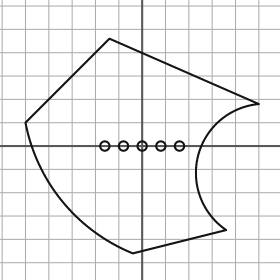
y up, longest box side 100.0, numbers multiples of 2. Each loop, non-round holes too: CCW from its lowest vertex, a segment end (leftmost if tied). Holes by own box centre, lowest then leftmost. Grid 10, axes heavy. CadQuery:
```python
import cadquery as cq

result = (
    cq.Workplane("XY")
    .moveTo(-4.0, -46.0)
    .lineTo(36.0, -36.0)
    .threePointArc((24.0, -4.0), (50.0, 18.0))
    .lineTo(-14.0, 46.0)
    .lineTo(-50.0, 10.0)
    .threePointArc((-34.0, -24.0), (-4.0, -46.0))
    .close()
    .moveTo(-16.0, 0.0)
    .circle(2.0)
    .moveTo(-8.0, 0.0)
    .circle(2.0)
    .moveTo(0.0, 0.0)
    .circle(2.0)
    .moveTo(8.0, 0.0)
    .circle(2.0)
    .moveTo(16.0, 0.0)
    .circle(2.0)
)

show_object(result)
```